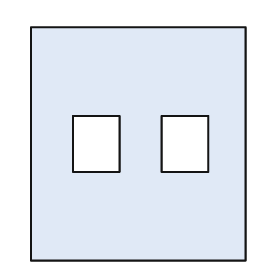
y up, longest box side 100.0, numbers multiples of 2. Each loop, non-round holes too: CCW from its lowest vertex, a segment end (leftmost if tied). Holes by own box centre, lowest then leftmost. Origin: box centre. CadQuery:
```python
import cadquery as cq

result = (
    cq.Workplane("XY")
    .moveTo(-46.0, -50.0)
    .lineTo(46.0, -50.0)
    .lineTo(46.0, 50.0)
    .lineTo(-46.0, 50.0)
    .close()
    .moveTo(-28.0, -12.0)
    .lineTo(-8.0, -12.0)
    .lineTo(-8.0, 12.0)
    .lineTo(-28.0, 12.0)
    .close()
    .moveTo(10.0, -12.0)
    .lineTo(30.0, -12.0)
    .lineTo(30.0, 12.0)
    .lineTo(10.0, 12.0)
    .close()
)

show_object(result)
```